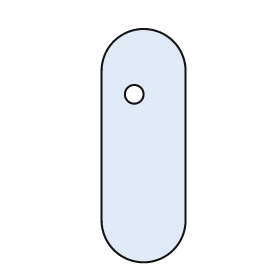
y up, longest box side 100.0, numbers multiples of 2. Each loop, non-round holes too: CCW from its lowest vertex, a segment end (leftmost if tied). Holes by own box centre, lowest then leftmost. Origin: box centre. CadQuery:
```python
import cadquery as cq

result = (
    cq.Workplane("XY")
    .moveTo(-18.0, -32.0)
    .threePointArc((0.0, -50.0), (18.0, -32.0))
    .lineTo(18.0, 32.0)
    .threePointArc((0.0, 50.0), (-18.0, 32.0))
    .close()
    .moveTo(-4.0, 22.0)
    .circle(4.0)
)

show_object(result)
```